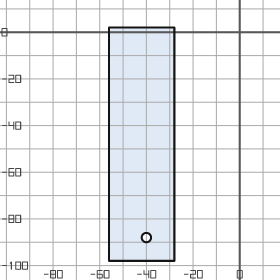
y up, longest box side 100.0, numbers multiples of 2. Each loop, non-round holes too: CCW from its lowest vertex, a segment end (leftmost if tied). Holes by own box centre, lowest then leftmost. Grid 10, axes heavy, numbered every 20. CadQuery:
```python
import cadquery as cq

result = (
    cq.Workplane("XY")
    .moveTo(-56.0, -98.0)
    .lineTo(-28.0, -98.0)
    .lineTo(-28.0, 2.0)
    .lineTo(-56.0, 2.0)
    .close()
    .moveTo(-40.0, -88.0)
    .circle(2.0)
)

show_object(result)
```